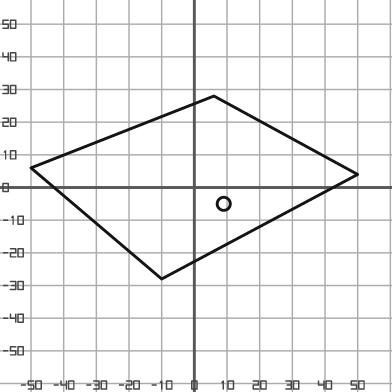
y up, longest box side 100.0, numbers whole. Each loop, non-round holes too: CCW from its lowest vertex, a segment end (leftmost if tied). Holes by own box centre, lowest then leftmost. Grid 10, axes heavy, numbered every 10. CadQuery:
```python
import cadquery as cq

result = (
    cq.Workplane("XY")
    .moveTo(-10.0, -28.0)
    .lineTo(50.0, 4.0)
    .lineTo(6.0, 28.0)
    .lineTo(-50.0, 6.0)
    .close()
    .moveTo(9.0, -5.0)
    .circle(2.0)
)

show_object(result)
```